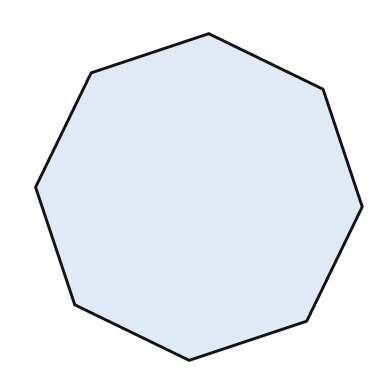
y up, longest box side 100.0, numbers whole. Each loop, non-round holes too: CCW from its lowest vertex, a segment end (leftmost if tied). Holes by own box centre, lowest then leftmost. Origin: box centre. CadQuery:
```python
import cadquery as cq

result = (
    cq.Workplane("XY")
    .moveTo(-3.0, -50.0)
    .lineTo(33.0, -38.0)
    .lineTo(50.0, -3.0)
    .lineTo(38.0, 33.0)
    .lineTo(3.0, 50.0)
    .lineTo(-33.0, 38.0)
    .lineTo(-50.0, 3.0)
    .lineTo(-38.0, -33.0)
    .close()
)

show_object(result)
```